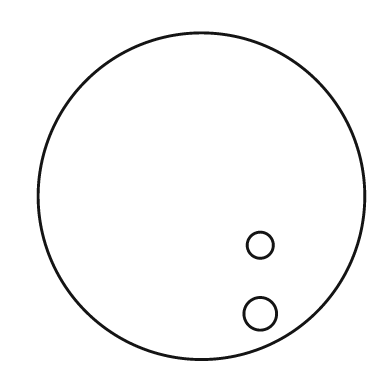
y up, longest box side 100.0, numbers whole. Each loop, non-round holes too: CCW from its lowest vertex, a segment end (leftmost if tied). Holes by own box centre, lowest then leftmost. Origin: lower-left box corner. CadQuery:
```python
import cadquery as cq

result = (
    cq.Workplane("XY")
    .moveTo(50.0, 50.0)
    .circle(50.0)
    .moveTo(68.0, 14.0)
    .circle(5.0)
    .moveTo(68.0, 35.0)
    .circle(4.0)
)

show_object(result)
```